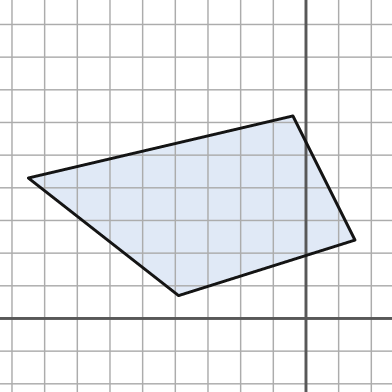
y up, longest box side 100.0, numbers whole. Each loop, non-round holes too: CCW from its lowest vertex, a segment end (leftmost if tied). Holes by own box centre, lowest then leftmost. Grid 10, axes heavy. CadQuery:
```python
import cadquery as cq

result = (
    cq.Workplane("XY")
    .moveTo(-39.0, 7.0)
    .lineTo(15.0, 24.0)
    .lineTo(-4.0, 62.0)
    .lineTo(-85.0, 43.0)
    .close()
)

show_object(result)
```